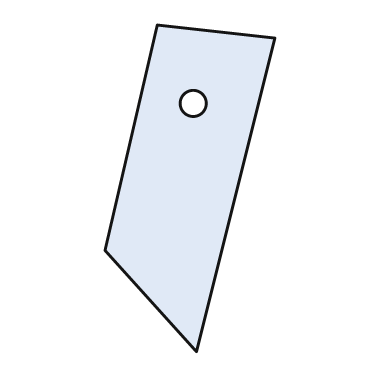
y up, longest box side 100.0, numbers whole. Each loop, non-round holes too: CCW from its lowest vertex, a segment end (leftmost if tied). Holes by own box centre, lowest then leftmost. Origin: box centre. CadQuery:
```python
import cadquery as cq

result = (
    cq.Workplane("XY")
    .moveTo(2.0, -50.0)
    .lineTo(26.0, 46.0)
    .lineTo(-10.0, 50.0)
    .lineTo(-26.0, -19.0)
    .close()
    .moveTo(1.0, 26.0)
    .circle(4.0)
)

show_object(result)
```